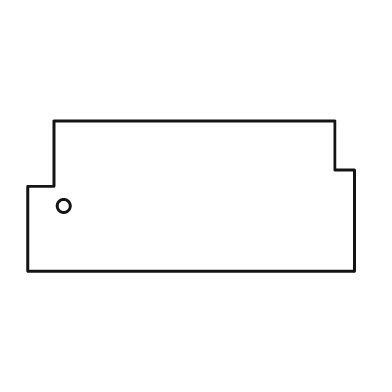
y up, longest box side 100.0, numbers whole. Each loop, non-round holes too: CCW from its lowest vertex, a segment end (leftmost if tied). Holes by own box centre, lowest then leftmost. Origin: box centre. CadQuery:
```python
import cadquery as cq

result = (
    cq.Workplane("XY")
    .moveTo(-50.0, -23.0)
    .lineTo(50.0, -23.0)
    .lineTo(50.0, 8.0)
    .lineTo(44.0, 8.0)
    .lineTo(44.0, 23.0)
    .lineTo(-42.0, 23.0)
    .lineTo(-42.0, 3.0)
    .lineTo(-50.0, 3.0)
    .close()
    .moveTo(-39.0, -3.0)
    .circle(2.0)
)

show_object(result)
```